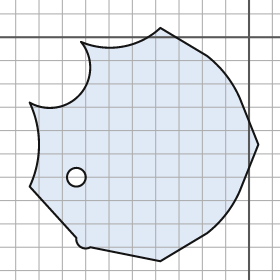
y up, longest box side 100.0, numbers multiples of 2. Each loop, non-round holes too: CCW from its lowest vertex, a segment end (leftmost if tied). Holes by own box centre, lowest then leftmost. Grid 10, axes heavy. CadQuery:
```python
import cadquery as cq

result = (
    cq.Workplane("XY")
    .moveTo(-38.0, -96.0)
    .lineTo(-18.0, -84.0)
    .threePointArc((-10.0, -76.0), (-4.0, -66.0))
    .lineTo(4.0, -46.0)
    .lineTo(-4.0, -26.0)
    .threePointArc((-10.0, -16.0), (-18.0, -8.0))
    .lineTo(-38.0, 4.0)
    .threePointArc((-54.0, -4.0), (-72.0, -2.0))
    .threePointArc((-72.0, -24.0), (-94.0, -28.0))
    .threePointArc((-90.0, -46.0), (-94.0, -64.0))
    .lineTo(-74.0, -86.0)
    .threePointArc((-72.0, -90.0), (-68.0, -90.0))
    .close()
    .moveTo(-74.0, -60.0)
    .circle(4.0)
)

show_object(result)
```